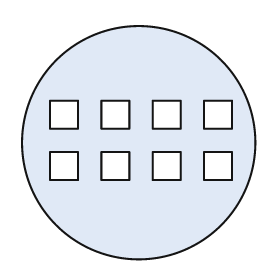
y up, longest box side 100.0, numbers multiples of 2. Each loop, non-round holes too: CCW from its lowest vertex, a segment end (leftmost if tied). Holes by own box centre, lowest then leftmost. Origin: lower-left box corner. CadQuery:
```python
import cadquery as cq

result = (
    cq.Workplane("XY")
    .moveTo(50.0, 50.0)
    .circle(50.0)
    .moveTo(12.0, 34.0)
    .lineTo(24.0, 34.0)
    .lineTo(24.0, 46.0)
    .lineTo(12.0, 46.0)
    .close()
    .moveTo(34.0, 34.0)
    .lineTo(46.0, 34.0)
    .lineTo(46.0, 46.0)
    .lineTo(34.0, 46.0)
    .close()
    .moveTo(56.0, 34.0)
    .lineTo(68.0, 34.0)
    .lineTo(68.0, 46.0)
    .lineTo(56.0, 46.0)
    .close()
    .moveTo(78.0, 34.0)
    .lineTo(90.0, 34.0)
    .lineTo(90.0, 46.0)
    .lineTo(78.0, 46.0)
    .close()
    .moveTo(12.0, 56.0)
    .lineTo(24.0, 56.0)
    .lineTo(24.0, 68.0)
    .lineTo(12.0, 68.0)
    .close()
    .moveTo(34.0, 56.0)
    .lineTo(46.0, 56.0)
    .lineTo(46.0, 68.0)
    .lineTo(34.0, 68.0)
    .close()
    .moveTo(56.0, 56.0)
    .lineTo(68.0, 56.0)
    .lineTo(68.0, 68.0)
    .lineTo(56.0, 68.0)
    .close()
    .moveTo(78.0, 56.0)
    .lineTo(90.0, 56.0)
    .lineTo(90.0, 68.0)
    .lineTo(78.0, 68.0)
    .close()
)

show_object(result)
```